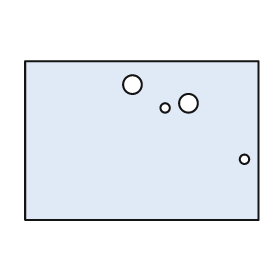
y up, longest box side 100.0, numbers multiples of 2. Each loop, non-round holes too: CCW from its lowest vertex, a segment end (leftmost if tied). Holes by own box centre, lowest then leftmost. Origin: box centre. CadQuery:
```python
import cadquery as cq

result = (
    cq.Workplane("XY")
    .moveTo(-50.0, -34.0)
    .lineTo(50.0, -34.0)
    .lineTo(50.0, 34.0)
    .lineTo(-50.0, 34.0)
    .close()
    .moveTo(44.0, -8.0)
    .circle(2.0)
    .moveTo(10.0, 14.0)
    .circle(2.0)
    .moveTo(20.0, 16.0)
    .circle(4.0)
    .moveTo(-4.0, 24.0)
    .circle(4.0)
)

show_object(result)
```